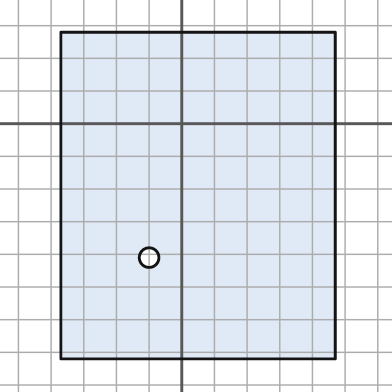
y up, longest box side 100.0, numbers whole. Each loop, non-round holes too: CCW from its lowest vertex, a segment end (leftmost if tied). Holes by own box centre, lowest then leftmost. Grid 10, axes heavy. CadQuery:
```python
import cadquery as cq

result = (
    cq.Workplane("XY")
    .moveTo(-37.0, -72.0)
    .lineTo(47.0, -72.0)
    .lineTo(47.0, 28.0)
    .lineTo(-37.0, 28.0)
    .close()
    .moveTo(-10.0, -41.0)
    .circle(3.0)
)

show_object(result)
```